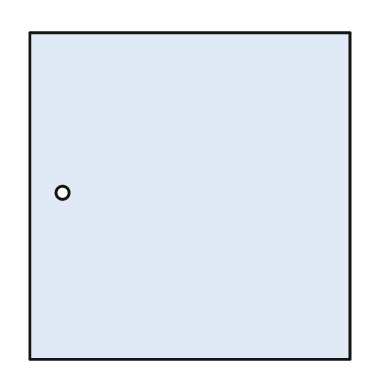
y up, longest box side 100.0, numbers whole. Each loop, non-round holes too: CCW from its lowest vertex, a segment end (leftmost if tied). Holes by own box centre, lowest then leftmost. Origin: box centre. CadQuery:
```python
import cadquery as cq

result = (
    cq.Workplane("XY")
    .moveTo(-49.0, -50.0)
    .lineTo(49.0, -50.0)
    .lineTo(49.0, 50.0)
    .lineTo(-49.0, 50.0)
    .close()
    .moveTo(-39.0, 1.0)
    .circle(2.0)
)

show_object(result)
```